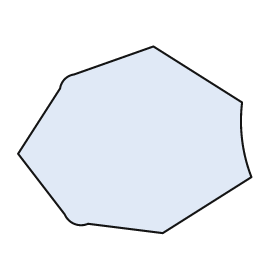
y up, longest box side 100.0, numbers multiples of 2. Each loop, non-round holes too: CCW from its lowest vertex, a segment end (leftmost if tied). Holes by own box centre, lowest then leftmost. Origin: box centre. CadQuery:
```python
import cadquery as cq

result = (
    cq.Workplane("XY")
    .moveTo(12.0, -40.0)
    .lineTo(50.0, -16.0)
    .threePointArc((46.0, 0.0), (46.0, 16.0))
    .lineTo(8.0, 40.0)
    .lineTo(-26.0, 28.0)
    .threePointArc((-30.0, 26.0), (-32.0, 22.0))
    .lineTo(-50.0, -6.0)
    .lineTo(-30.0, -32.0)
    .threePointArc((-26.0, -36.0), (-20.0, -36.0))
    .close()
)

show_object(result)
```